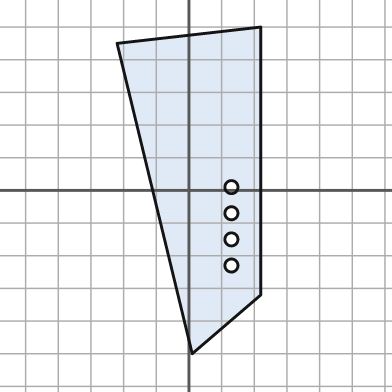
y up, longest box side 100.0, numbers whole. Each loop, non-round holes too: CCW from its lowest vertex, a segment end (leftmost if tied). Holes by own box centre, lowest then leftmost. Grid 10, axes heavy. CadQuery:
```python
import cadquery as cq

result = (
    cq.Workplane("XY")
    .moveTo(1.0, -50.0)
    .lineTo(22.0, -32.0)
    .lineTo(22.0, 50.0)
    .lineTo(-22.0, 45.0)
    .close()
    .moveTo(13.0, -23.0)
    .circle(2.0)
    .moveTo(13.0, -15.0)
    .circle(2.0)
    .moveTo(13.0, -7.0)
    .circle(2.0)
    .moveTo(13.0, 1.0)
    .circle(2.0)
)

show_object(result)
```